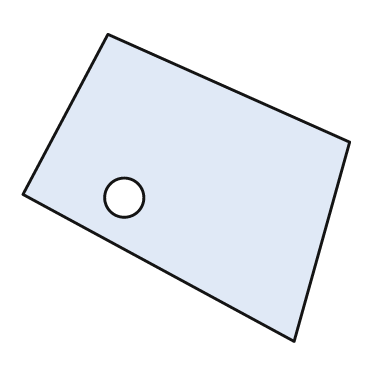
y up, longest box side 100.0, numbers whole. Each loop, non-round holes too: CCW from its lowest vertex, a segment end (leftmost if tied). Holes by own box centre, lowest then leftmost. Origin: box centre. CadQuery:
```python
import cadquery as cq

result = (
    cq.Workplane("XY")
    .moveTo(33.0, -47.0)
    .lineTo(50.0, 14.0)
    .lineTo(-24.0, 47.0)
    .lineTo(-50.0, -2.0)
    .close()
    .moveTo(-19.0, -3.0)
    .circle(6.0)
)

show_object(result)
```